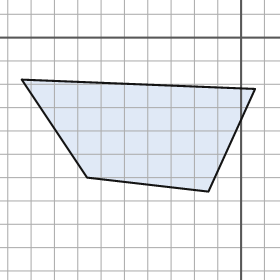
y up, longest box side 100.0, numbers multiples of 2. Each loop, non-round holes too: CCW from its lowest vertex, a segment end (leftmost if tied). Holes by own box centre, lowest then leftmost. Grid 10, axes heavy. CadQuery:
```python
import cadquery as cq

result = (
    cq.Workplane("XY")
    .moveTo(-14.0, -66.0)
    .lineTo(6.0, -22.0)
    .lineTo(-94.0, -18.0)
    .lineTo(-66.0, -60.0)
    .close()
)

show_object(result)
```